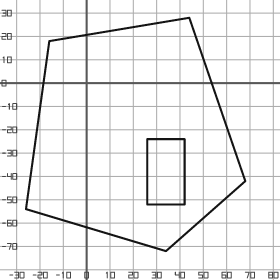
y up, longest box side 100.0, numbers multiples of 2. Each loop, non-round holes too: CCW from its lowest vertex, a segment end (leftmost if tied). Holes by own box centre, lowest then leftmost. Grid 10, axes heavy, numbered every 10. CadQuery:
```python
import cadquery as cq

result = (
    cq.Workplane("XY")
    .moveTo(34.0, -72.0)
    .lineTo(68.0, -42.0)
    .lineTo(44.0, 28.0)
    .lineTo(-16.0, 18.0)
    .lineTo(-26.0, -54.0)
    .close()
    .moveTo(26.0, -52.0)
    .lineTo(42.0, -52.0)
    .lineTo(42.0, -24.0)
    .lineTo(26.0, -24.0)
    .close()
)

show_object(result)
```